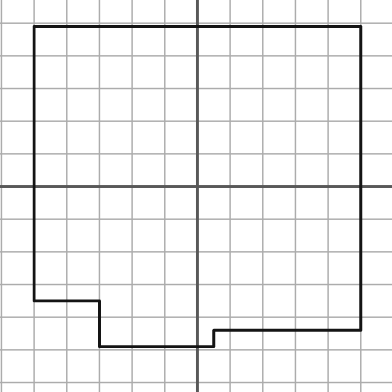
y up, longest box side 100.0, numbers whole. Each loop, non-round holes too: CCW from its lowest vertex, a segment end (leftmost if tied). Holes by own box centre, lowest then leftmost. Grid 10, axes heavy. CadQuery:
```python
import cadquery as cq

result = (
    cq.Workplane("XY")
    .moveTo(-30.0, -49.0)
    .lineTo(5.0, -49.0)
    .lineTo(5.0, -44.0)
    .lineTo(50.0, -44.0)
    .lineTo(50.0, 49.0)
    .lineTo(-50.0, 49.0)
    .lineTo(-50.0, -35.0)
    .lineTo(-30.0, -35.0)
    .close()
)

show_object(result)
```